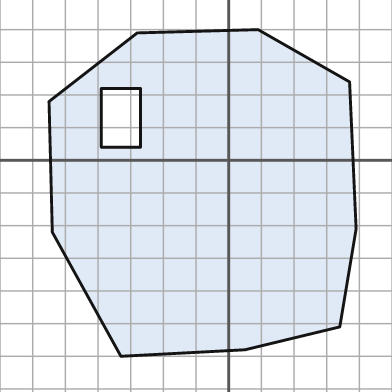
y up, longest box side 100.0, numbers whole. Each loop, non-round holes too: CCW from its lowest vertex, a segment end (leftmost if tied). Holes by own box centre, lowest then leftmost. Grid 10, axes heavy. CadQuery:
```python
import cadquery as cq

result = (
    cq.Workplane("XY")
    .moveTo(-33.0, -60.0)
    .lineTo(5.0, -58.0)
    .lineTo(34.0, -51.0)
    .lineTo(39.0, -21.0)
    .lineTo(37.0, 24.0)
    .lineTo(9.0, 40.0)
    .lineTo(-28.0, 39.0)
    .lineTo(-55.0, 18.0)
    .lineTo(-54.0, -22.0)
    .close()
    .moveTo(-39.0, 4.0)
    .lineTo(-27.0, 4.0)
    .lineTo(-27.0, 22.0)
    .lineTo(-39.0, 22.0)
    .close()
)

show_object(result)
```